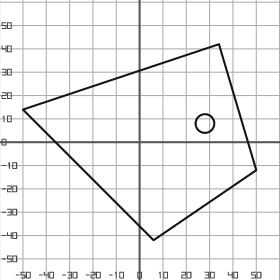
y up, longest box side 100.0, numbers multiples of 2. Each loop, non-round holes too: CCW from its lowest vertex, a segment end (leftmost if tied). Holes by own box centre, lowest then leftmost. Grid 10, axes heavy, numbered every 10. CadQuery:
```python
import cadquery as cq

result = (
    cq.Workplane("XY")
    .moveTo(6.0, -42.0)
    .lineTo(50.0, -12.0)
    .lineTo(34.0, 42.0)
    .lineTo(-50.0, 14.0)
    .close()
    .moveTo(28.0, 8.0)
    .circle(4.0)
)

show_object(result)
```